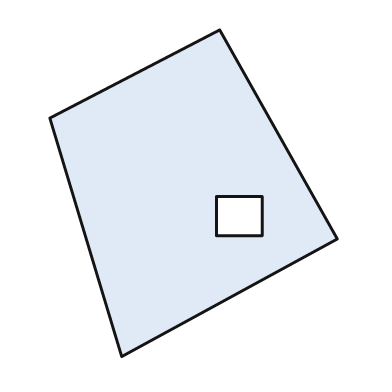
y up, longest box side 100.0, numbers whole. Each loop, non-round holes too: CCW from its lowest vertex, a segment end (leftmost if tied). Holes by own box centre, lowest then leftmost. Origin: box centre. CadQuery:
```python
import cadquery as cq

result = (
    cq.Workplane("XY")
    .moveTo(-22.0, -50.0)
    .lineTo(44.0, -14.0)
    .lineTo(8.0, 50.0)
    .lineTo(-44.0, 23.0)
    .close()
    .moveTo(7.0, -13.0)
    .lineTo(21.0, -13.0)
    .lineTo(21.0, -1.0)
    .lineTo(7.0, -1.0)
    .close()
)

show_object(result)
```